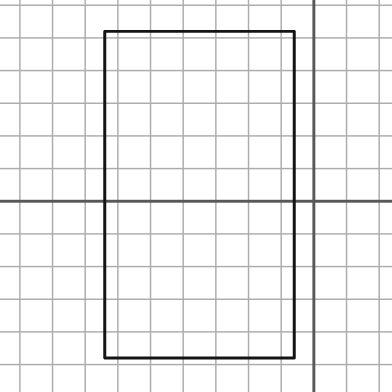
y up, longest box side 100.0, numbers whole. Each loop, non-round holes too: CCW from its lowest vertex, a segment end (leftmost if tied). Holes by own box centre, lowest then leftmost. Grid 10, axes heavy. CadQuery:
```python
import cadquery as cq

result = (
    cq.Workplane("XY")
    .moveTo(-64.0, -48.0)
    .lineTo(-6.0, -48.0)
    .lineTo(-6.0, 52.0)
    .lineTo(-64.0, 52.0)
    .close()
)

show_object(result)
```